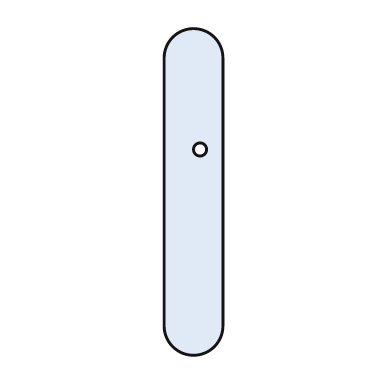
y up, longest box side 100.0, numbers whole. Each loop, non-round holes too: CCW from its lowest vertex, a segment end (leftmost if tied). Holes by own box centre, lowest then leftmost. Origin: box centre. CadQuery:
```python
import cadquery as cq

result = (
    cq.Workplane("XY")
    .moveTo(-9.0, -41.0)
    .threePointArc((0.0, -50.0), (9.0, -41.0))
    .lineTo(9.0, 41.0)
    .threePointArc((0.0, 50.0), (-9.0, 41.0))
    .close()
    .moveTo(2.0, 13.0)
    .circle(2.0)
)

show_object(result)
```